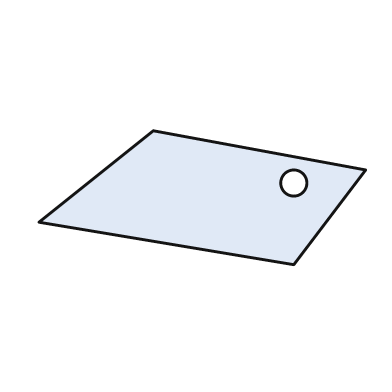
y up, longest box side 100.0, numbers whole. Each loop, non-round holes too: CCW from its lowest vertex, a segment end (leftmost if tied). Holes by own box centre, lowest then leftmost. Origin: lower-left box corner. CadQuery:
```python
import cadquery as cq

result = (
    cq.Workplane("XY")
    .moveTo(78.0, 0.0)
    .lineTo(100.0, 29.0)
    .lineTo(35.0, 41.0)
    .lineTo(0.0, 13.0)
    .close()
    .moveTo(78.0, 25.0)
    .circle(4.0)
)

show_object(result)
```